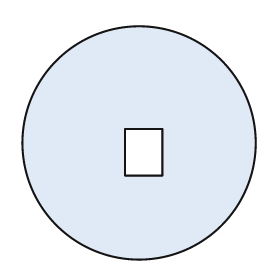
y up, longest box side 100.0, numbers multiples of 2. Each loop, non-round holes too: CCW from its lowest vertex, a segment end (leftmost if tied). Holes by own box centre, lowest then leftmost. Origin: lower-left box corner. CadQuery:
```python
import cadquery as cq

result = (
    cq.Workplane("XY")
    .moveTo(50.0, 50.0)
    .circle(50.0)
    .moveTo(44.0, 36.0)
    .lineTo(60.0, 36.0)
    .lineTo(60.0, 56.0)
    .lineTo(44.0, 56.0)
    .close()
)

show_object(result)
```